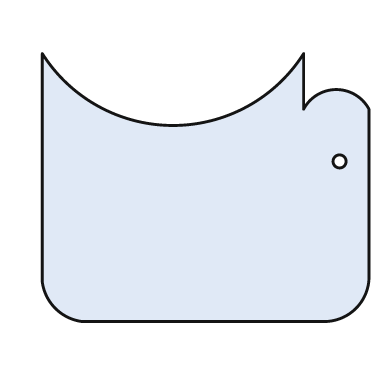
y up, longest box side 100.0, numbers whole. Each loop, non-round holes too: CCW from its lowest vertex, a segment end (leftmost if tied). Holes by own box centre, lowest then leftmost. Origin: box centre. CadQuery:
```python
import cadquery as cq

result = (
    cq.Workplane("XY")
    .moveTo(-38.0, -41.0)
    .lineTo(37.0, -41.0)
    .threePointArc((46.0, -37.0), (50.0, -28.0))
    .lineTo(50.0, 24.0)
    .threePointArc((40.0, 30.0), (30.0, 24.0))
    .lineTo(30.0, 41.0)
    .threePointArc((-10.0, 19.0), (-50.0, 41.0))
    .lineTo(-50.0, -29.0)
    .threePointArc((-46.0, -37.0), (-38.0, -41.0))
    .close()
    .moveTo(41.0, 8.0)
    .circle(2.0)
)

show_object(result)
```